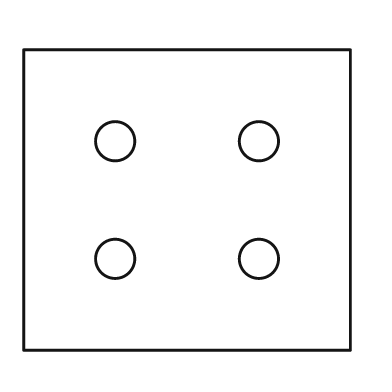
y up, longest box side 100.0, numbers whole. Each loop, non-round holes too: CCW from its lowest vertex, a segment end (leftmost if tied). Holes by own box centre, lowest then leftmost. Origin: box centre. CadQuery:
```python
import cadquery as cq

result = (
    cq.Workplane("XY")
    .moveTo(-50.0, -46.0)
    .lineTo(50.0, -46.0)
    .lineTo(50.0, 46.0)
    .lineTo(-50.0, 46.0)
    .close()
    .moveTo(-22.0, -18.0)
    .circle(6.0)
    .moveTo(22.0, -18.0)
    .circle(6.0)
    .moveTo(-22.0, 18.0)
    .circle(6.0)
    .moveTo(22.0, 18.0)
    .circle(6.0)
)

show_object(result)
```